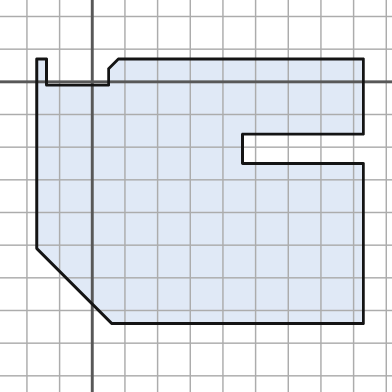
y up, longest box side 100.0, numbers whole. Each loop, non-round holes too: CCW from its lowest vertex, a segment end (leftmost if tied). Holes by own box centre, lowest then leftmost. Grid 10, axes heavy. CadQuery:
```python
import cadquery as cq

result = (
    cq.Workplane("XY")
    .moveTo(6.0, -74.0)
    .lineTo(83.0, -74.0)
    .lineTo(83.0, -25.0)
    .lineTo(46.0, -25.0)
    .lineTo(46.0, -16.0)
    .lineTo(83.0, -16.0)
    .lineTo(83.0, 7.0)
    .lineTo(8.0, 7.0)
    .lineTo(5.0, 4.0)
    .lineTo(5.0, -1.0)
    .lineTo(-14.0, -1.0)
    .lineTo(-14.0, 7.0)
    .lineTo(-17.0, 7.0)
    .lineTo(-17.0, -51.0)
    .close()
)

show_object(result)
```